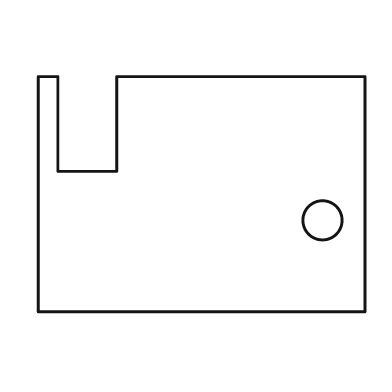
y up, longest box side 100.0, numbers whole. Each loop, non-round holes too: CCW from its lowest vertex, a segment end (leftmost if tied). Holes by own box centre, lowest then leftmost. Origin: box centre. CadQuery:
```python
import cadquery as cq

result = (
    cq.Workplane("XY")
    .moveTo(-50.0, -36.0)
    .lineTo(50.0, -36.0)
    .lineTo(50.0, 36.0)
    .lineTo(-26.0, 36.0)
    .lineTo(-26.0, 7.0)
    .lineTo(-44.0, 7.0)
    .lineTo(-44.0, 36.0)
    .lineTo(-50.0, 36.0)
    .close()
    .moveTo(37.0, -8.0)
    .circle(6.0)
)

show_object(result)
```